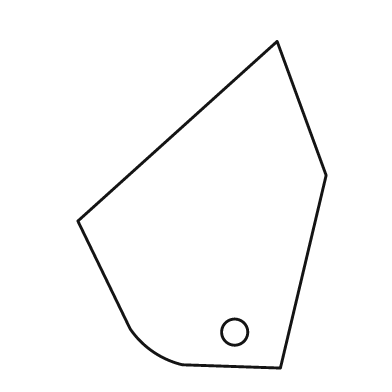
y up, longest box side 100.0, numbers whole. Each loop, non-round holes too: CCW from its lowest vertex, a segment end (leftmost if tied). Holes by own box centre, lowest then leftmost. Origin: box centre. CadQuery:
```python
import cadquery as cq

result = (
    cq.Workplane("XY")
    .moveTo(24.0, -50.0)
    .lineTo(38.0, 9.0)
    .lineTo(23.0, 50.0)
    .lineTo(-38.0, -5.0)
    .lineTo(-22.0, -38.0)
    .threePointArc((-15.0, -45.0), (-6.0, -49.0))
    .close()
    .moveTo(10.0, -39.0)
    .circle(4.0)
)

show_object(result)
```